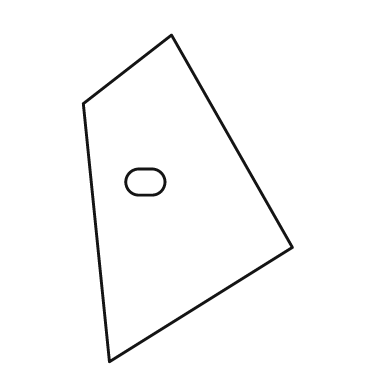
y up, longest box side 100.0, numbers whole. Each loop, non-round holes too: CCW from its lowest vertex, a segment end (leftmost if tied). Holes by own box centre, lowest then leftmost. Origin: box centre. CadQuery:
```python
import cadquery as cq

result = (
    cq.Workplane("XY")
    .moveTo(-24.0, -50.0)
    .lineTo(32.0, -15.0)
    .lineTo(-5.0, 50.0)
    .lineTo(-32.0, 29.0)
    .close()
    .moveTo(-15.0, 1.0)
    .lineTo(-11.0, 1.0)
    .threePointArc((-7.0, 5.0), (-11.0, 9.0))
    .lineTo(-15.0, 9.0)
    .threePointArc((-19.0, 5.0), (-15.0, 1.0))
    .close()
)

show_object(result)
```